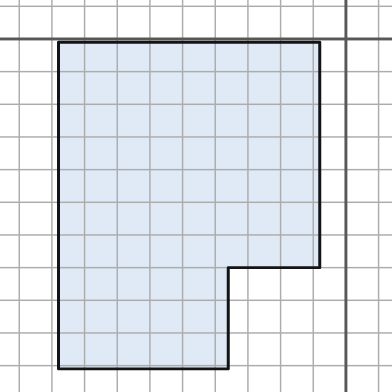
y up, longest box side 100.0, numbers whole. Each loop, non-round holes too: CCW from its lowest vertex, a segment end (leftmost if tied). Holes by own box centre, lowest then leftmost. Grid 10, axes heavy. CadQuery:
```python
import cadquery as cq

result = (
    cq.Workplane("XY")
    .moveTo(-88.0, -101.0)
    .lineTo(-36.0, -101.0)
    .lineTo(-36.0, -70.0)
    .lineTo(-8.0, -70.0)
    .lineTo(-8.0, -1.0)
    .lineTo(-88.0, -1.0)
    .close()
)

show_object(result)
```